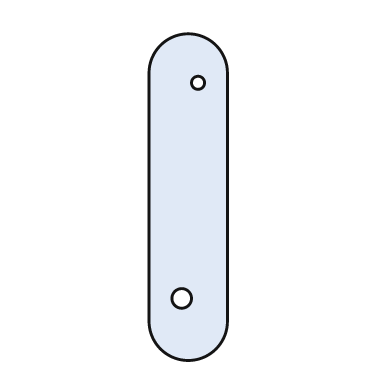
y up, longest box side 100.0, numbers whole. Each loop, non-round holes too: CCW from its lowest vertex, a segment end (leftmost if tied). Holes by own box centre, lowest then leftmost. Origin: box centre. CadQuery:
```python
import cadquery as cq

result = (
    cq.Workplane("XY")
    .moveTo(-12.0, -38.0)
    .threePointArc((0.0, -50.0), (12.0, -38.0))
    .lineTo(12.0, 38.0)
    .threePointArc((0.0, 50.0), (-12.0, 38.0))
    .close()
    .moveTo(-2.0, -31.0)
    .circle(3.0)
    .moveTo(3.0, 35.0)
    .circle(2.0)
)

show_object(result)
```